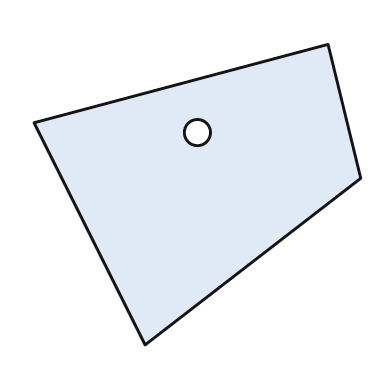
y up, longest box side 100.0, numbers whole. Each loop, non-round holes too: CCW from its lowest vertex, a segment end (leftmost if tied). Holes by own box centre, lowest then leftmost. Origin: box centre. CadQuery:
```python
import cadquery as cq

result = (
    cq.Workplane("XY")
    .moveTo(-16.0, -46.0)
    .lineTo(50.0, 5.0)
    .lineTo(40.0, 46.0)
    .lineTo(-50.0, 22.0)
    .close()
    .moveTo(0.0, 19.0)
    .circle(4.0)
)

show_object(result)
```